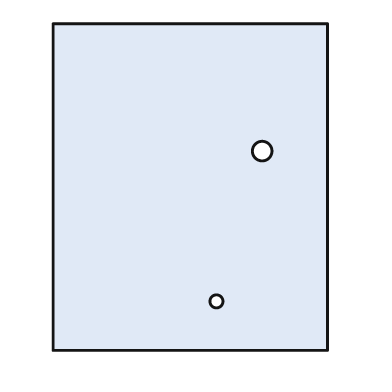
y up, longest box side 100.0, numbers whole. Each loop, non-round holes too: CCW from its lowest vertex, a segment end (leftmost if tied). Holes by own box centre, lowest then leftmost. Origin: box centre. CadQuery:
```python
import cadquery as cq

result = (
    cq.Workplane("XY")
    .moveTo(-42.0, -50.0)
    .lineTo(42.0, -50.0)
    .lineTo(42.0, 50.0)
    .lineTo(-42.0, 50.0)
    .close()
    .moveTo(8.0, -35.0)
    .circle(2.0)
    .moveTo(22.0, 11.0)
    .circle(3.0)
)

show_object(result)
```